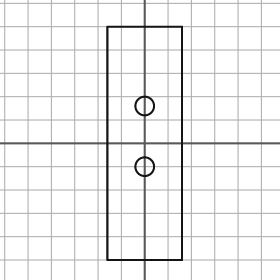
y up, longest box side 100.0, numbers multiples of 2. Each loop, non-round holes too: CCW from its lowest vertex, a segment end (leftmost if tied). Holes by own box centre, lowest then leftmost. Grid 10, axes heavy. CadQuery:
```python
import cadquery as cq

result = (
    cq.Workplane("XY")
    .moveTo(-16.0, -50.0)
    .lineTo(16.0, -50.0)
    .lineTo(16.0, 50.0)
    .lineTo(-16.0, 50.0)
    .close()
    .moveTo(0.0, -10.0)
    .circle(4.0)
    .moveTo(0.0, 16.0)
    .circle(4.0)
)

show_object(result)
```